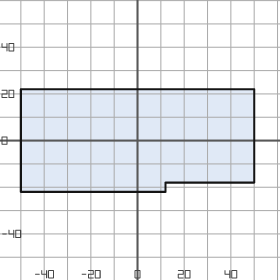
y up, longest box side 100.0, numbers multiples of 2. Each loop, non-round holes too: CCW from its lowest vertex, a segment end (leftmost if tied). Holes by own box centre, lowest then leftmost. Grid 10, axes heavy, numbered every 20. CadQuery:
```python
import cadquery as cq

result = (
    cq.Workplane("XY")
    .moveTo(-50.0, -22.0)
    .lineTo(12.0, -22.0)
    .lineTo(12.0, -18.0)
    .lineTo(50.0, -18.0)
    .lineTo(50.0, 22.0)
    .lineTo(-50.0, 22.0)
    .close()
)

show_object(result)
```